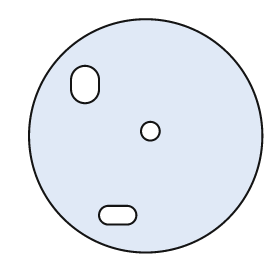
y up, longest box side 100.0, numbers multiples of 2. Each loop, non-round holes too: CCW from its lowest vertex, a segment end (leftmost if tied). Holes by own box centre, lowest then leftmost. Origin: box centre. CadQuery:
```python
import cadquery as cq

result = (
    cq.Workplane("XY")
    .moveTo(0.0, 0.0)
    .circle(50.0)
    .moveTo(-16.0, -38.0)
    .lineTo(-8.0, -38.0)
    .threePointArc((-4.0, -34.0), (-8.0, -30.0))
    .lineTo(-16.0, -30.0)
    .threePointArc((-20.0, -34.0), (-16.0, -38.0))
    .close()
    .moveTo(2.0, 2.0)
    .circle(4.0)
    .moveTo(-32.0, 20.0)
    .threePointArc((-26.0, 14.0), (-20.0, 20.0))
    .lineTo(-20.0, 24.0)
    .threePointArc((-26.0, 30.0), (-32.0, 24.0))
    .close()
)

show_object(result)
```